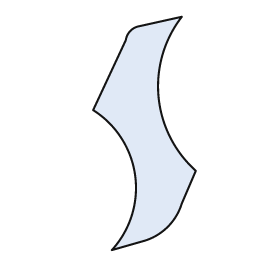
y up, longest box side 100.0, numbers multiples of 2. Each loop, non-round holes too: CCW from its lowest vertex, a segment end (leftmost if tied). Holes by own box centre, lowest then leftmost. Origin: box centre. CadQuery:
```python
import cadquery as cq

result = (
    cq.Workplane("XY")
    .moveTo(-14.0, -50.0)
    .lineTo(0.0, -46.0)
    .threePointArc((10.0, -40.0), (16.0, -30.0))
    .lineTo(22.0, -16.0)
    .threePointArc((6.0, 16.0), (16.0, 50.0))
    .lineTo(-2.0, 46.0)
    .threePointArc((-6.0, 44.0), (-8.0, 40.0))
    .lineTo(-22.0, 10.0)
    .threePointArc((-4.0, -18.0), (-14.0, -50.0))
    .close()
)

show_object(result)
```